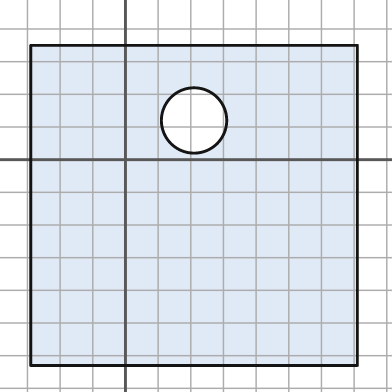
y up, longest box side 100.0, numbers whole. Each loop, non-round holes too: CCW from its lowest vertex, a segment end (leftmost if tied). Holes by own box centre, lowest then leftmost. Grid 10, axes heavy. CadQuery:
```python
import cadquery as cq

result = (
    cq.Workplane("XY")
    .moveTo(-29.0, -63.0)
    .lineTo(71.0, -63.0)
    .lineTo(71.0, 35.0)
    .lineTo(-29.0, 35.0)
    .close()
    .moveTo(21.0, 12.0)
    .circle(10.0)
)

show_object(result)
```